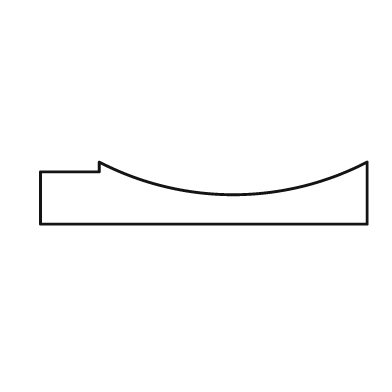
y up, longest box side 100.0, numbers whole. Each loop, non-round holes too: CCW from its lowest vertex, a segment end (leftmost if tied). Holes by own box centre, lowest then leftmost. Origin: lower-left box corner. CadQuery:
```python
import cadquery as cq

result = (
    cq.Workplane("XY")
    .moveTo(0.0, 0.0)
    .lineTo(100.0, 0.0)
    .lineTo(100.0, 19.0)
    .threePointArc((59.0, 9.0), (18.0, 19.0))
    .lineTo(18.0, 16.0)
    .lineTo(0.0, 16.0)
    .close()
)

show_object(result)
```